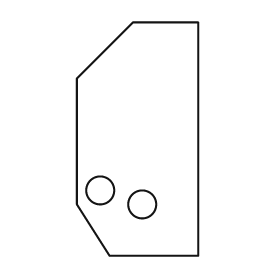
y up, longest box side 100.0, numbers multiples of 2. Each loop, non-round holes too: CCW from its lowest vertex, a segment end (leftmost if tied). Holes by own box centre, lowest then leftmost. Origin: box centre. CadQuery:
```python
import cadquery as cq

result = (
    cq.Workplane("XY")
    .moveTo(-12.0, -50.0)
    .lineTo(26.0, -50.0)
    .lineTo(26.0, 50.0)
    .lineTo(-2.0, 50.0)
    .lineTo(-26.0, 26.0)
    .lineTo(-26.0, -28.0)
    .close()
    .moveTo(2.0, -28.0)
    .circle(6.0)
    .moveTo(-16.0, -22.0)
    .circle(6.0)
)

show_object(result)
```